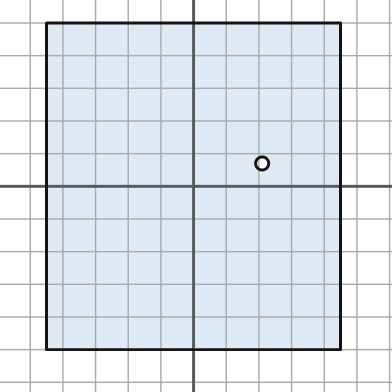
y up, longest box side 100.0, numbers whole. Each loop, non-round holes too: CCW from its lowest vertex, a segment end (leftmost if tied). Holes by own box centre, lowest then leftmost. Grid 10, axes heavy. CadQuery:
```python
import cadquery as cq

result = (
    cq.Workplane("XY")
    .moveTo(-45.0, -50.0)
    .lineTo(45.0, -50.0)
    .lineTo(45.0, 50.0)
    .lineTo(-45.0, 50.0)
    .close()
    .moveTo(21.0, 7.0)
    .circle(2.0)
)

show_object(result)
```